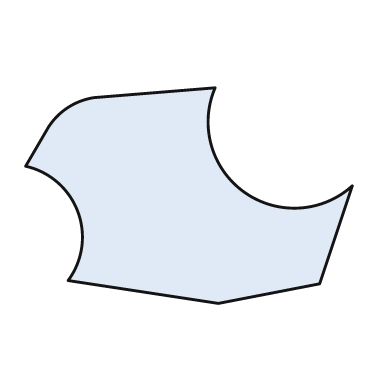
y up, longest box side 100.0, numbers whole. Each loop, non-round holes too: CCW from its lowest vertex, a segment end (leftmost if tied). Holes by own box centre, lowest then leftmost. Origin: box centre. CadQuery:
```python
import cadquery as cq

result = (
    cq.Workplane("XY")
    .moveTo(9.0, -33.0)
    .lineTo(40.0, -27.0)
    .lineTo(50.0, 3.0)
    .threePointArc((17.0, 1.0), (8.0, 33.0))
    .lineTo(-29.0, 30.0)
    .threePointArc((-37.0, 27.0), (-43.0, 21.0))
    .lineTo(-50.0, 9.0)
    .threePointArc((-34.0, -5.0), (-37.0, -26.0))
    .close()
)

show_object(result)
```